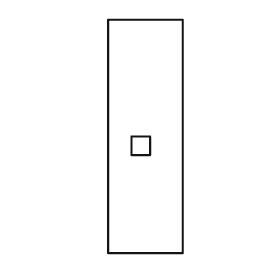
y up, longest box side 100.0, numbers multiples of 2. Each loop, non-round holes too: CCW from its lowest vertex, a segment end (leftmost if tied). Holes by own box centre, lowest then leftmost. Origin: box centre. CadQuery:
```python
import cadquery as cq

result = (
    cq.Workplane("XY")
    .moveTo(-16.0, -50.0)
    .lineTo(16.0, -50.0)
    .lineTo(16.0, 50.0)
    .lineTo(-16.0, 50.0)
    .close()
    .moveTo(-6.0, -8.0)
    .lineTo(2.0, -8.0)
    .lineTo(2.0, 0.0)
    .lineTo(-6.0, 0.0)
    .close()
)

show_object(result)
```